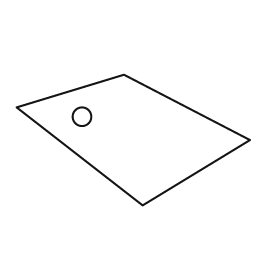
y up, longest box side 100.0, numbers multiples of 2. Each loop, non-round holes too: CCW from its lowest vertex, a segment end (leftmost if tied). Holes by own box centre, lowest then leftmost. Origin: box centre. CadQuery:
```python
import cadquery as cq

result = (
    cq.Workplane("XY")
    .moveTo(4.0, -28.0)
    .lineTo(50.0, 0.0)
    .lineTo(-4.0, 28.0)
    .lineTo(-50.0, 14.0)
    .close()
    .moveTo(-22.0, 10.0)
    .circle(4.0)
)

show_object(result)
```